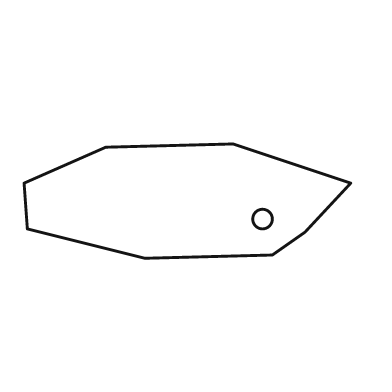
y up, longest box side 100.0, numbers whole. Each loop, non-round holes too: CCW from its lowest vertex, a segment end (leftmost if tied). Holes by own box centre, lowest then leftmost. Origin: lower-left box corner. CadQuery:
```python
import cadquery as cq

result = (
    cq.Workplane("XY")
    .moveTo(37.0, 0.0)
    .lineTo(76.0, 1.0)
    .lineTo(86.0, 8.0)
    .lineTo(100.0, 23.0)
    .lineTo(64.0, 35.0)
    .lineTo(25.0, 34.0)
    .lineTo(0.0, 23.0)
    .lineTo(1.0, 9.0)
    .close()
    .moveTo(73.0, 12.0)
    .circle(3.0)
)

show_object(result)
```